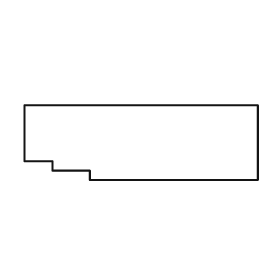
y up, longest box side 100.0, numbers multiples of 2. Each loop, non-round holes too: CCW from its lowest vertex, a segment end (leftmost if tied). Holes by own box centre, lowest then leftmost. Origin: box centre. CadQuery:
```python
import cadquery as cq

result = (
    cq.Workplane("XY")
    .moveTo(-22.0, -16.0)
    .lineTo(50.0, -16.0)
    .lineTo(50.0, 16.0)
    .lineTo(-50.0, 16.0)
    .lineTo(-50.0, -8.0)
    .lineTo(-38.0, -8.0)
    .lineTo(-38.0, -12.0)
    .lineTo(-22.0, -12.0)
    .close()
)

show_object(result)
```